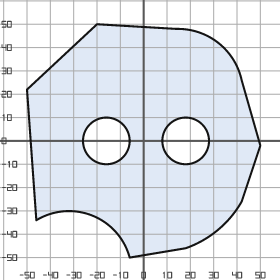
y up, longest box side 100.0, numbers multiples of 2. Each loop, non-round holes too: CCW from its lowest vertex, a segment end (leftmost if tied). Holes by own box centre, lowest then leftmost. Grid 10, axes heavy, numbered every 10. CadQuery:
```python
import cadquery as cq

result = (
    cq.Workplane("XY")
    .moveTo(-6.0, -50.0)
    .lineTo(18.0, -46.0)
    .threePointArc((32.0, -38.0), (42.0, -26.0))
    .lineTo(50.0, -2.0)
    .lineTo(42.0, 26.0)
    .threePointArc((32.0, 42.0), (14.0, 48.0))
    .lineTo(-20.0, 50.0)
    .lineTo(-50.0, 22.0)
    .lineTo(-46.0, -34.0)
    .threePointArc((-22.0, -32.0), (-6.0, -50.0))
    .close()
    .moveTo(-16.0, 0.0)
    .circle(10.0)
    .moveTo(18.0, 0.0)
    .circle(10.0)
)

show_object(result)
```